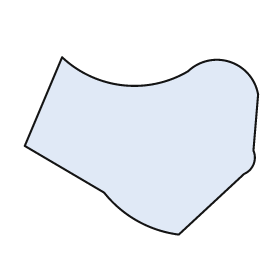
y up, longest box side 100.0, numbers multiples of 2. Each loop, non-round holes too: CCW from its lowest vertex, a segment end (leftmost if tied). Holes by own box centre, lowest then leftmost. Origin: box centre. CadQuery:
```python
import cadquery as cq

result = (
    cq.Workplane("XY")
    .moveTo(16.0, -38.0)
    .lineTo(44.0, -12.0)
    .threePointArc((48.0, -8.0), (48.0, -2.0))
    .lineTo(50.0, 22.0)
    .threePointArc((38.0, 36.0), (20.0, 32.0))
    .threePointArc((-8.0, 26.0), (-34.0, 38.0))
    .lineTo(-50.0, 0.0)
    .lineTo(-16.0, -20.0)
    .threePointArc((-2.0, -32.0), (16.0, -38.0))
    .close()
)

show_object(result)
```